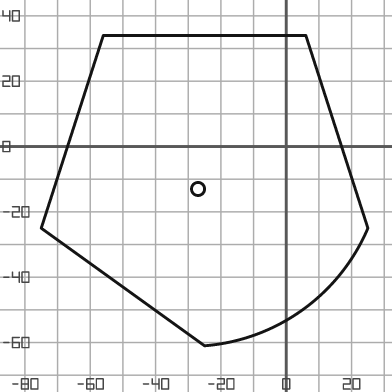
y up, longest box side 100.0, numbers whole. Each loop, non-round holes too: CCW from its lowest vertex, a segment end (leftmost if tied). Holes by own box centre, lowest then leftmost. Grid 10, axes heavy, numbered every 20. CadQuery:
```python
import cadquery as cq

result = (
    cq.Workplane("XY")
    .moveTo(-25.0, -61.0)
    .threePointArc((5.0, -50.0), (25.0, -25.0))
    .lineTo(6.0, 34.0)
    .lineTo(-56.0, 34.0)
    .lineTo(-75.0, -25.0)
    .close()
    .moveTo(-27.0, -13.0)
    .circle(2.0)
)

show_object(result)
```